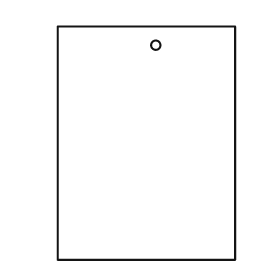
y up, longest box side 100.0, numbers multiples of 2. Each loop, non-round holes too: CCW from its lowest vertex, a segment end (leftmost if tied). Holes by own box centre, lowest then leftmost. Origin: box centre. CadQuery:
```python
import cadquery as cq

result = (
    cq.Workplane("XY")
    .moveTo(-38.0, -50.0)
    .lineTo(38.0, -50.0)
    .lineTo(38.0, 50.0)
    .lineTo(-38.0, 50.0)
    .close()
    .moveTo(4.0, 42.0)
    .circle(2.0)
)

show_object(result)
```